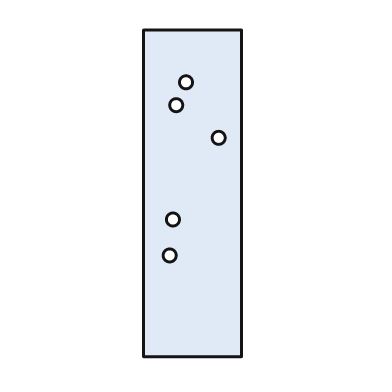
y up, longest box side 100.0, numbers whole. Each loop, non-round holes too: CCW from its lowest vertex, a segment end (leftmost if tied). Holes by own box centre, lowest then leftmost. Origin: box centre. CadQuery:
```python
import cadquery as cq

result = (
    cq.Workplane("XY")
    .moveTo(-15.0, -50.0)
    .lineTo(15.0, -50.0)
    .lineTo(15.0, 50.0)
    .lineTo(-15.0, 50.0)
    .close()
    .moveTo(-7.0, -19.0)
    .circle(2.0)
    .moveTo(-6.0, -8.0)
    .circle(2.0)
    .moveTo(8.0, 17.0)
    .circle(2.0)
    .moveTo(-5.0, 27.0)
    .circle(2.0)
    .moveTo(-2.0, 34.0)
    .circle(2.0)
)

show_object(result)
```